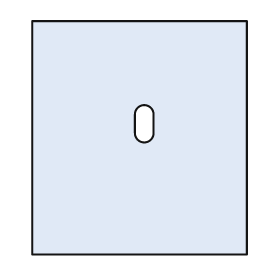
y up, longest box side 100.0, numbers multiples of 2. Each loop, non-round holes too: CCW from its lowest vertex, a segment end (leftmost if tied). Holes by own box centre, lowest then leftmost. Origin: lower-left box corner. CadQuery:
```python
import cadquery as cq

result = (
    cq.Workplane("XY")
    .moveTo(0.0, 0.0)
    .lineTo(92.0, 0.0)
    .lineTo(92.0, 100.0)
    .lineTo(0.0, 100.0)
    .close()
    .moveTo(44.0, 52.0)
    .threePointArc((48.0, 48.0), (52.0, 52.0))
    .lineTo(52.0, 60.0)
    .threePointArc((48.0, 64.0), (44.0, 60.0))
    .close()
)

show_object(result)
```